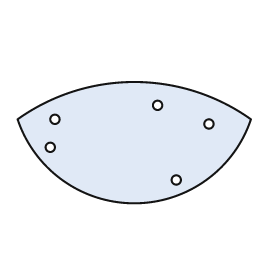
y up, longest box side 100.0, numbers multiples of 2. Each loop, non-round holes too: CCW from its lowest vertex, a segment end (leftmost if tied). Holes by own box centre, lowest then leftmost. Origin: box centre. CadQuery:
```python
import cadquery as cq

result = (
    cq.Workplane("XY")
    .moveTo(-50.0, 10.0)
    .threePointArc((0.0, -26.0), (50.0, 10.0))
    .threePointArc((0.0, 26.0), (-50.0, 10.0))
    .close()
    .moveTo(18.0, -16.0)
    .circle(2.0)
    .moveTo(-36.0, -2.0)
    .circle(2.0)
    .moveTo(32.0, 8.0)
    .circle(2.0)
    .moveTo(-34.0, 10.0)
    .circle(2.0)
    .moveTo(10.0, 16.0)
    .circle(2.0)
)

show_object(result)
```